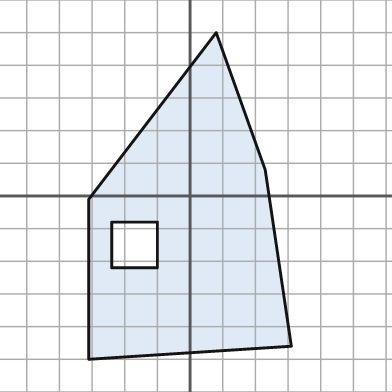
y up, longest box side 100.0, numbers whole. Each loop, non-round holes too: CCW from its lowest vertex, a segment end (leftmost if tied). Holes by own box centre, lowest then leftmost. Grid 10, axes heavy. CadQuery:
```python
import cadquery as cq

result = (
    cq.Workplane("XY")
    .moveTo(-31.0, -50.0)
    .lineTo(31.0, -46.0)
    .lineTo(23.0, 8.0)
    .lineTo(8.0, 50.0)
    .lineTo(-31.0, -1.0)
    .close()
    .moveTo(-24.0, -22.0)
    .lineTo(-10.0, -22.0)
    .lineTo(-10.0, -8.0)
    .lineTo(-24.0, -8.0)
    .close()
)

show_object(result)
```